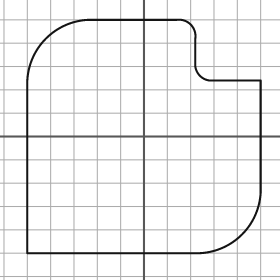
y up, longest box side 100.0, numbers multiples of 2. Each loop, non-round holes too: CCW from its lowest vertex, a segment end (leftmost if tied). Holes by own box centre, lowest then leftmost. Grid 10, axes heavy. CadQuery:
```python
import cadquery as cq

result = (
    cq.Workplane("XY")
    .moveTo(-50.0, -50.0)
    .lineTo(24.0, -50.0)
    .threePointArc((42.0, -42.0), (50.0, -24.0))
    .lineTo(50.0, 24.0)
    .lineTo(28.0, 24.0)
    .threePointArc((24.0, 26.0), (22.0, 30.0))
    .lineTo(22.0, 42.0)
    .threePointArc((20.0, 48.0), (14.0, 50.0))
    .lineTo(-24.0, 50.0)
    .threePointArc((-42.0, 42.0), (-50.0, 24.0))
    .close()
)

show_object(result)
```